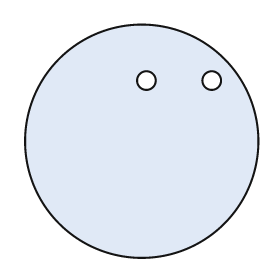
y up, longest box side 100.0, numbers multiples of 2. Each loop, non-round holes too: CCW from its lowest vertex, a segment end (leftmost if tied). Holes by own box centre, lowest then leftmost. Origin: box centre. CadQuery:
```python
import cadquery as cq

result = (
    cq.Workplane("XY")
    .moveTo(0.0, 0.0)
    .circle(50.0)
    .moveTo(2.0, 26.0)
    .circle(4.0)
    .moveTo(30.0, 26.0)
    .circle(4.0)
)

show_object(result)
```